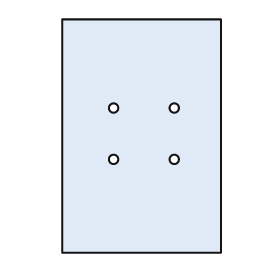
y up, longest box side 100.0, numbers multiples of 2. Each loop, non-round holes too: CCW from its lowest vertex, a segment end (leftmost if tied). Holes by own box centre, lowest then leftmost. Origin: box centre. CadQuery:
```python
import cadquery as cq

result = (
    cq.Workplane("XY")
    .moveTo(-34.0, -50.0)
    .lineTo(34.0, -50.0)
    .lineTo(34.0, 50.0)
    .lineTo(-34.0, 50.0)
    .close()
    .moveTo(-12.0, -10.0)
    .circle(2.0)
    .moveTo(14.0, -10.0)
    .circle(2.0)
    .moveTo(-12.0, 12.0)
    .circle(2.0)
    .moveTo(14.0, 12.0)
    .circle(2.0)
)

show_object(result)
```